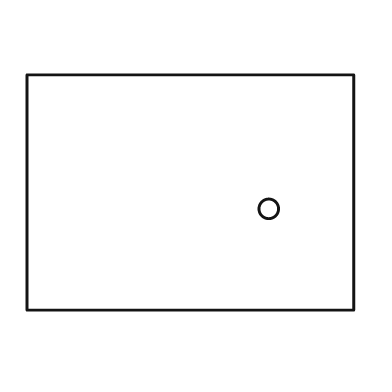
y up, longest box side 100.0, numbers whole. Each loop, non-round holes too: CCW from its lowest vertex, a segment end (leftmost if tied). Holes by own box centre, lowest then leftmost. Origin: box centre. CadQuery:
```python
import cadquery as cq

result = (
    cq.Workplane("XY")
    .moveTo(-50.0, -36.0)
    .lineTo(50.0, -36.0)
    .lineTo(50.0, 36.0)
    .lineTo(-50.0, 36.0)
    .close()
    .moveTo(24.0, -5.0)
    .circle(3.0)
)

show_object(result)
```